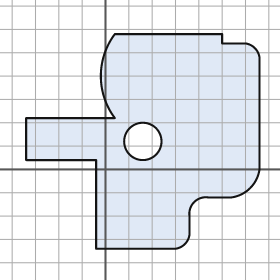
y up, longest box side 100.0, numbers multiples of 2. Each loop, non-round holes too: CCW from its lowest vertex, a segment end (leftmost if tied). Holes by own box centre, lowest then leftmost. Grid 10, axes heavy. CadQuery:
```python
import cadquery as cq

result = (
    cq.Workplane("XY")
    .moveTo(-4.0, -34.0)
    .lineTo(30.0, -34.0)
    .threePointArc((34.0, -32.0), (36.0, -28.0))
    .lineTo(36.0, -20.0)
    .threePointArc((38.0, -14.0), (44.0, -12.0))
    .lineTo(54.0, -12.0)
    .threePointArc((62.0, -8.0), (66.0, 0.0))
    .lineTo(66.0, 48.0)
    .threePointArc((64.0, 52.0), (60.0, 54.0))
    .lineTo(50.0, 54.0)
    .lineTo(50.0, 58.0)
    .lineTo(4.0, 58.0)
    .threePointArc((-2.0, 40.0), (4.0, 22.0))
    .lineTo(-34.0, 22.0)
    .lineTo(-34.0, 4.0)
    .lineTo(-4.0, 4.0)
    .close()
    .moveTo(16.0, 12.0)
    .circle(8.0)
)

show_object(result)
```